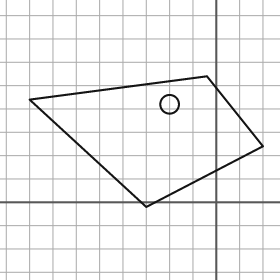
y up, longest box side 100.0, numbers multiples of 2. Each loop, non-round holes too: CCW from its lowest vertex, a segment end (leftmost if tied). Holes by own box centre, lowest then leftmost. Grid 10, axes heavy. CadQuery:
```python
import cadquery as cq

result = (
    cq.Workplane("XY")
    .moveTo(-30.0, -2.0)
    .lineTo(20.0, 24.0)
    .lineTo(-4.0, 54.0)
    .lineTo(-80.0, 44.0)
    .close()
    .moveTo(-20.0, 42.0)
    .circle(4.0)
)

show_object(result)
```